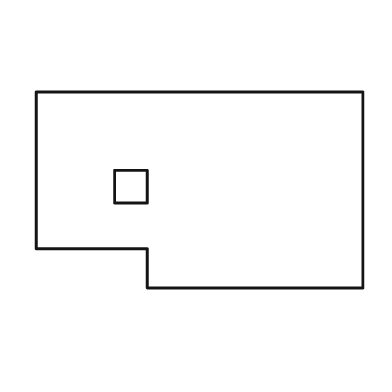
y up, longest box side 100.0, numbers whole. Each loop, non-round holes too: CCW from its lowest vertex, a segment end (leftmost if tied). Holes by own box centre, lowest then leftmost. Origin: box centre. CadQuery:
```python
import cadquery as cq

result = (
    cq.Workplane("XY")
    .moveTo(-16.0, -30.0)
    .lineTo(50.0, -30.0)
    .lineTo(50.0, 30.0)
    .lineTo(-50.0, 30.0)
    .lineTo(-50.0, -18.0)
    .lineTo(-16.0, -18.0)
    .close()
    .moveTo(-26.0, -4.0)
    .lineTo(-16.0, -4.0)
    .lineTo(-16.0, 6.0)
    .lineTo(-26.0, 6.0)
    .close()
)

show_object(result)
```